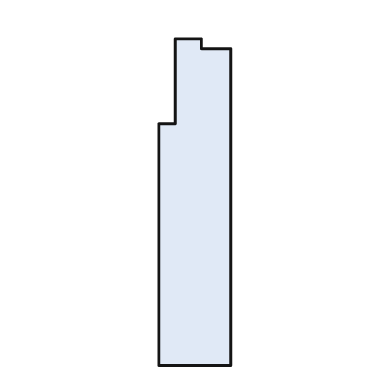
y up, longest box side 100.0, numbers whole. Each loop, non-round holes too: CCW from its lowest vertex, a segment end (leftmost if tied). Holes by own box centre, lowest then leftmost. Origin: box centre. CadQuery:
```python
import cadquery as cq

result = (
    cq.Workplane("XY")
    .moveTo(-11.0, -50.0)
    .lineTo(11.0, -50.0)
    .lineTo(11.0, 47.0)
    .lineTo(2.0, 47.0)
    .lineTo(2.0, 50.0)
    .lineTo(-6.0, 50.0)
    .lineTo(-6.0, 24.0)
    .lineTo(-11.0, 24.0)
    .close()
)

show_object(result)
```